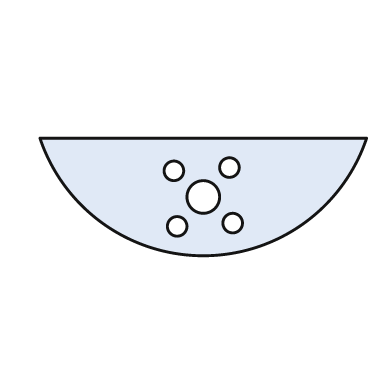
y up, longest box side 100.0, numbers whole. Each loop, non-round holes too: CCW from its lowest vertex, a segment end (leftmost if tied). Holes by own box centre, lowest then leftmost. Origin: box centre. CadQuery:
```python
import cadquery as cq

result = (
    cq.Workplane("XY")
    .moveTo(-50.0, 18.0)
    .threePointArc((0.0, -18.0), (50.0, 18.0))
    .close()
    .moveTo(-8.0, -9.0)
    .circle(3.0)
    .moveTo(9.0, -8.0)
    .circle(3.0)
    .moveTo(0.0, 0.0)
    .circle(5.0)
    .moveTo(-9.0, 8.0)
    .circle(3.0)
    .moveTo(8.0, 9.0)
    .circle(3.0)
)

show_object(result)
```